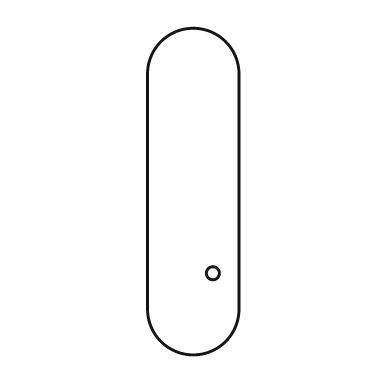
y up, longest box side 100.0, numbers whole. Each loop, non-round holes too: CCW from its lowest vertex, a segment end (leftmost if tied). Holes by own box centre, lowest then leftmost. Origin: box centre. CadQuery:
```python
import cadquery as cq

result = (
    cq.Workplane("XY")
    .moveTo(-14.0, -36.0)
    .threePointArc((0.0, -50.0), (14.0, -36.0))
    .lineTo(14.0, 36.0)
    .threePointArc((0.0, 50.0), (-14.0, 36.0))
    .close()
    .moveTo(6.0, -25.0)
    .circle(2.0)
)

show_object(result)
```